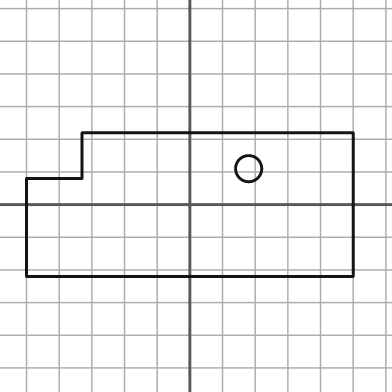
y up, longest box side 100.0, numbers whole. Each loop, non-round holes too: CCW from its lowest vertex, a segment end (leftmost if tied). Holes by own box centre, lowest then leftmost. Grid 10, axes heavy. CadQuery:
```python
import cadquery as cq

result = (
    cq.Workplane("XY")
    .moveTo(-50.0, -22.0)
    .lineTo(50.0, -22.0)
    .lineTo(50.0, 22.0)
    .lineTo(-33.0, 22.0)
    .lineTo(-33.0, 8.0)
    .lineTo(-50.0, 8.0)
    .close()
    .moveTo(18.0, 11.0)
    .circle(4.0)
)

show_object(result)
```